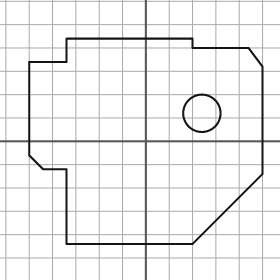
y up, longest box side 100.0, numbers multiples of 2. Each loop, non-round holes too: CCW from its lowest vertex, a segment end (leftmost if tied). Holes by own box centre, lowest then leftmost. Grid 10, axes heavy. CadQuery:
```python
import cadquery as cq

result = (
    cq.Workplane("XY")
    .moveTo(-34.0, -44.0)
    .lineTo(20.0, -44.0)
    .lineTo(50.0, -14.0)
    .lineTo(50.0, 32.0)
    .lineTo(44.0, 40.0)
    .lineTo(20.0, 40.0)
    .lineTo(20.0, 44.0)
    .lineTo(-34.0, 44.0)
    .lineTo(-34.0, 34.0)
    .lineTo(-50.0, 34.0)
    .lineTo(-50.0, -6.0)
    .lineTo(-44.0, -12.0)
    .lineTo(-34.0, -12.0)
    .close()
    .moveTo(24.0, 12.0)
    .circle(8.0)
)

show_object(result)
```